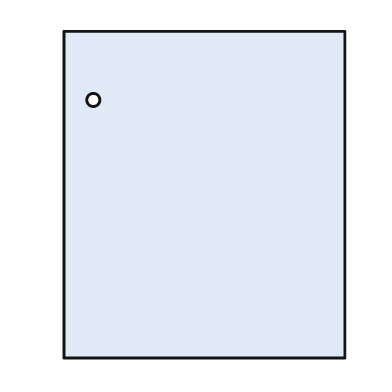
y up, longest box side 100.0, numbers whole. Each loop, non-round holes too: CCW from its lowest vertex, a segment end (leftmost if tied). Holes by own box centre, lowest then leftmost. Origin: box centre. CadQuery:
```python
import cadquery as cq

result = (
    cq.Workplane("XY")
    .moveTo(-43.0, -50.0)
    .lineTo(43.0, -50.0)
    .lineTo(43.0, 50.0)
    .lineTo(-43.0, 50.0)
    .close()
    .moveTo(-34.0, 29.0)
    .circle(2.0)
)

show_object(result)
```